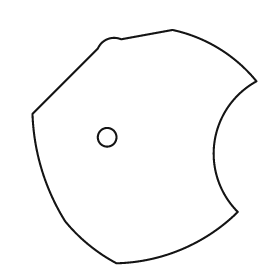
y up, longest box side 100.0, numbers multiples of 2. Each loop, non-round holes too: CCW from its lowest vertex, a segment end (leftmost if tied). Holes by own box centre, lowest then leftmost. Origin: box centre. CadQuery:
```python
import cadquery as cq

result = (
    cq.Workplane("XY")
    .moveTo(-12.0, -50.0)
    .threePointArc((16.0, -44.0), (40.0, -28.0))
    .threePointArc((30.0, 2.0), (48.0, 28.0))
    .threePointArc((32.0, 42.0), (12.0, 50.0))
    .lineTo(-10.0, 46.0)
    .threePointArc((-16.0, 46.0), (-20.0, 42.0))
    .lineTo(-48.0, 14.0)
    .threePointArc((-44.0, -10.0), (-34.0, -32.0))
    .threePointArc((-24.0, -42.0), (-12.0, -50.0))
    .close()
    .moveTo(-16.0, 4.0)
    .circle(4.0)
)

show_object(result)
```